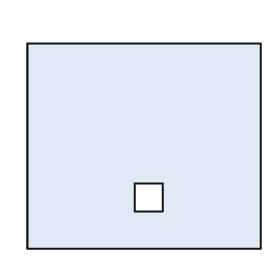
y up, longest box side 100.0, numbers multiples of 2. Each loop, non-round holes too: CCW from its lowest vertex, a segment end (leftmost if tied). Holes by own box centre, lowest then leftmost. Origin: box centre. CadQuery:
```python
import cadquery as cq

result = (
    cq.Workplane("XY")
    .moveTo(-50.0, -44.0)
    .lineTo(50.0, -44.0)
    .lineTo(50.0, 44.0)
    .lineTo(-50.0, 44.0)
    .close()
    .moveTo(-4.0, -28.0)
    .lineTo(8.0, -28.0)
    .lineTo(8.0, -16.0)
    .lineTo(-4.0, -16.0)
    .close()
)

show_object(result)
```